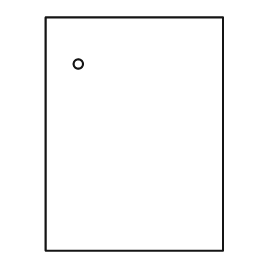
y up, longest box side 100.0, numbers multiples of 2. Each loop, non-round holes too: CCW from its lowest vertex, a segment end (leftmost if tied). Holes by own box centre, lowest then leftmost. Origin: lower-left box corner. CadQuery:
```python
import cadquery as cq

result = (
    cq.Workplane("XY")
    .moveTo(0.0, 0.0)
    .lineTo(76.0, 0.0)
    .lineTo(76.0, 100.0)
    .lineTo(0.0, 100.0)
    .close()
    .moveTo(14.0, 80.0)
    .circle(2.0)
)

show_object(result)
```